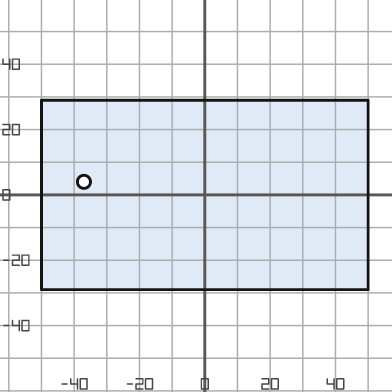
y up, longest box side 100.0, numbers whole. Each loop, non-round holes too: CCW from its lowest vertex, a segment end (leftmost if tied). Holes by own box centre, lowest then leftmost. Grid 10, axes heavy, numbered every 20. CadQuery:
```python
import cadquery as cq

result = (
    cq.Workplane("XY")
    .moveTo(-50.0, -29.0)
    .lineTo(50.0, -29.0)
    .lineTo(50.0, 29.0)
    .lineTo(-50.0, 29.0)
    .close()
    .moveTo(-37.0, 4.0)
    .circle(2.0)
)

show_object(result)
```